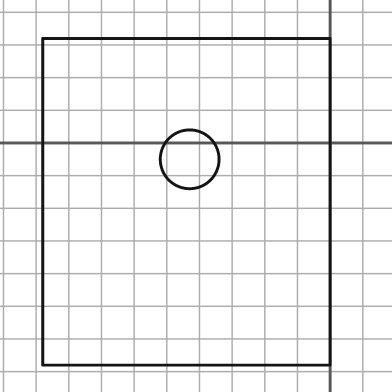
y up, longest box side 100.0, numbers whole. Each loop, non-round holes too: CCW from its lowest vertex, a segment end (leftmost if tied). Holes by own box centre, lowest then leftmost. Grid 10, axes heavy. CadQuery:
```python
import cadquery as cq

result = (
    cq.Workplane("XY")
    .moveTo(-88.0, -68.0)
    .lineTo(0.0, -68.0)
    .lineTo(0.0, 32.0)
    .lineTo(-88.0, 32.0)
    .close()
    .moveTo(-43.0, -5.0)
    .circle(9.0)
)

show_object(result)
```